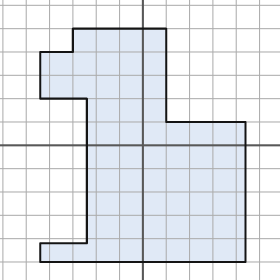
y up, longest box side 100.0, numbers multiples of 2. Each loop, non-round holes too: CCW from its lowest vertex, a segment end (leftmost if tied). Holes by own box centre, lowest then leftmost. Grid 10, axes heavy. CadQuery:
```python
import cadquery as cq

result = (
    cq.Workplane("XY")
    .moveTo(-44.0, -50.0)
    .lineTo(44.0, -50.0)
    .lineTo(44.0, 10.0)
    .lineTo(10.0, 10.0)
    .lineTo(10.0, 50.0)
    .lineTo(-30.0, 50.0)
    .lineTo(-30.0, 40.0)
    .lineTo(-44.0, 40.0)
    .lineTo(-44.0, 20.0)
    .lineTo(-24.0, 20.0)
    .lineTo(-24.0, -42.0)
    .lineTo(-44.0, -42.0)
    .close()
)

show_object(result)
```